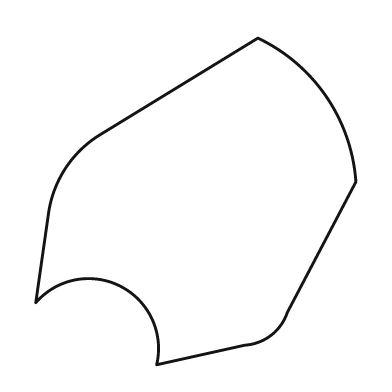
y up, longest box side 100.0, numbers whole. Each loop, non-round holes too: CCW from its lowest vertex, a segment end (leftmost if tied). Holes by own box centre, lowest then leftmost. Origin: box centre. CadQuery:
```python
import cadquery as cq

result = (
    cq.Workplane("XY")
    .moveTo(-12.0, -50.0)
    .lineTo(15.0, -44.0)
    .threePointArc((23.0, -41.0), (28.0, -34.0))
    .lineTo(49.0, 6.0)
    .threePointArc((40.0, 32.0), (19.0, 50.0))
    .lineTo(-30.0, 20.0)
    .threePointArc((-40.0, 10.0), (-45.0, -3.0))
    .lineTo(-49.0, -31.0)
    .threePointArc((-23.0, -26.0), (-12.0, -50.0))
    .close()
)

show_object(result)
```